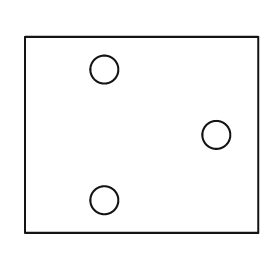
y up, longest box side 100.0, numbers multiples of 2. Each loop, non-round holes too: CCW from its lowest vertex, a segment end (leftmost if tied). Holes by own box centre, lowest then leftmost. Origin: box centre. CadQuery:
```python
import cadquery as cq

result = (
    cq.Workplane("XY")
    .moveTo(-50.0, -42.0)
    .lineTo(50.0, -42.0)
    .lineTo(50.0, 42.0)
    .lineTo(-50.0, 42.0)
    .close()
    .moveTo(-16.0, -28.0)
    .circle(6.0)
    .moveTo(32.0, 0.0)
    .circle(6.0)
    .moveTo(-16.0, 28.0)
    .circle(6.0)
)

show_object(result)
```